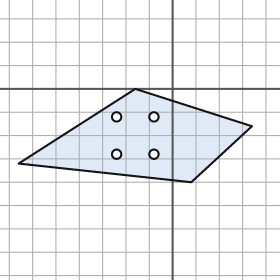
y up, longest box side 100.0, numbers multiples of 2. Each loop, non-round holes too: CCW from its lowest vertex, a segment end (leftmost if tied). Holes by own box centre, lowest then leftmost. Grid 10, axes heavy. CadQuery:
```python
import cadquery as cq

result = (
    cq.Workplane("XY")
    .moveTo(8.0, -40.0)
    .lineTo(34.0, -16.0)
    .lineTo(-16.0, 0.0)
    .lineTo(-66.0, -32.0)
    .close()
    .moveTo(-24.0, -28.0)
    .circle(2.0)
    .moveTo(-8.0, -28.0)
    .circle(2.0)
    .moveTo(-24.0, -12.0)
    .circle(2.0)
    .moveTo(-8.0, -12.0)
    .circle(2.0)
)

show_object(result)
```